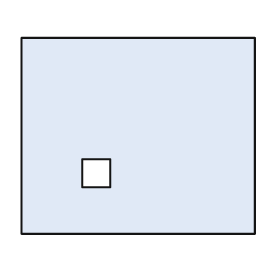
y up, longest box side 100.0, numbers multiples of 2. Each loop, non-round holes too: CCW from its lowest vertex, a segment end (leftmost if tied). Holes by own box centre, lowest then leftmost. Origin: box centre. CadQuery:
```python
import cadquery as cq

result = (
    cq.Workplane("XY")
    .moveTo(-50.0, -42.0)
    .lineTo(50.0, -42.0)
    .lineTo(50.0, 42.0)
    .lineTo(-50.0, 42.0)
    .close()
    .moveTo(-24.0, -22.0)
    .lineTo(-12.0, -22.0)
    .lineTo(-12.0, -10.0)
    .lineTo(-24.0, -10.0)
    .close()
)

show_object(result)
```